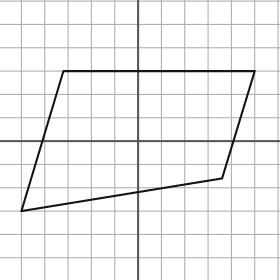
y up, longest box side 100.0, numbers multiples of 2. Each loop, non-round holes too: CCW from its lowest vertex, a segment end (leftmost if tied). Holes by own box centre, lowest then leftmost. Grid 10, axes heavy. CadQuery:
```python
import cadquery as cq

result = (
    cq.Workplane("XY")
    .moveTo(-50.0, -30.0)
    .lineTo(36.0, -16.0)
    .lineTo(50.0, 30.0)
    .lineTo(-32.0, 30.0)
    .close()
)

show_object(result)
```